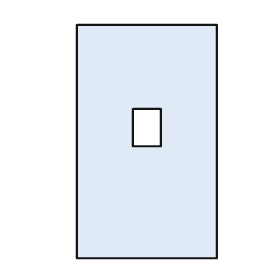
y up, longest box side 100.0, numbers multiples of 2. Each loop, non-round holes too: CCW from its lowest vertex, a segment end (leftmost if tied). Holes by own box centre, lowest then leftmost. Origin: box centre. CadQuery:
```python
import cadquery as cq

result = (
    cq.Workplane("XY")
    .moveTo(-30.0, -50.0)
    .lineTo(30.0, -50.0)
    .lineTo(30.0, 50.0)
    .lineTo(-30.0, 50.0)
    .close()
    .moveTo(-6.0, -2.0)
    .lineTo(6.0, -2.0)
    .lineTo(6.0, 14.0)
    .lineTo(-6.0, 14.0)
    .close()
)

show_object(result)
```